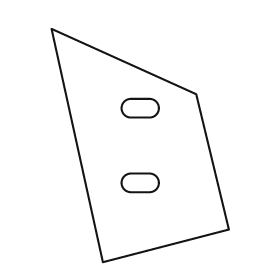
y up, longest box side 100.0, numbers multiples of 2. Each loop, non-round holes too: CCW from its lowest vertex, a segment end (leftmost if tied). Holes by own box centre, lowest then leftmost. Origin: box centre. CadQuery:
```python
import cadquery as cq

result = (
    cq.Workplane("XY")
    .moveTo(-16.0, -50.0)
    .lineTo(38.0, -36.0)
    .lineTo(24.0, 22.0)
    .lineTo(-38.0, 50.0)
    .close()
    .moveTo(-4.0, -20.0)
    .lineTo(4.0, -20.0)
    .threePointArc((8.0, -16.0), (4.0, -12.0))
    .lineTo(-4.0, -12.0)
    .threePointArc((-8.0, -16.0), (-4.0, -20.0))
    .close()
    .moveTo(-4.0, 12.0)
    .lineTo(4.0, 12.0)
    .threePointArc((8.0, 16.0), (4.0, 20.0))
    .lineTo(-4.0, 20.0)
    .threePointArc((-8.0, 16.0), (-4.0, 12.0))
    .close()
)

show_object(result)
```